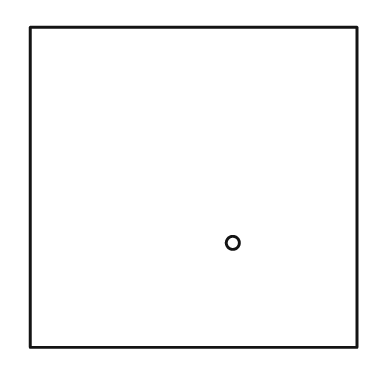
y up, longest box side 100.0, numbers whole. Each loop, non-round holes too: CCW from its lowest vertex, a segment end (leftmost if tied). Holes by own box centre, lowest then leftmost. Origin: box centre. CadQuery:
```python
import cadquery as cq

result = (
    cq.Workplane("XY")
    .moveTo(-50.0, -49.0)
    .lineTo(50.0, -49.0)
    .lineTo(50.0, 49.0)
    .lineTo(-50.0, 49.0)
    .close()
    .moveTo(12.0, -17.0)
    .circle(2.0)
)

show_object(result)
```